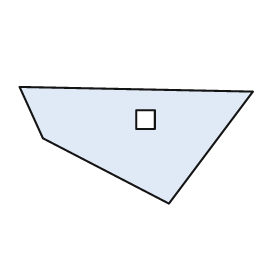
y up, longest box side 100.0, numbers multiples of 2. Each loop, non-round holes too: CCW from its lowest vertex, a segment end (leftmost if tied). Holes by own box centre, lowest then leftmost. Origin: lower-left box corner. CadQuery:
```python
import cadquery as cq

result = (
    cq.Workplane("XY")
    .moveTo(64.0, 0.0)
    .lineTo(100.0, 48.0)
    .lineTo(0.0, 50.0)
    .lineTo(10.0, 28.0)
    .close()
    .moveTo(50.0, 32.0)
    .lineTo(58.0, 32.0)
    .lineTo(58.0, 40.0)
    .lineTo(50.0, 40.0)
    .close()
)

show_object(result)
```